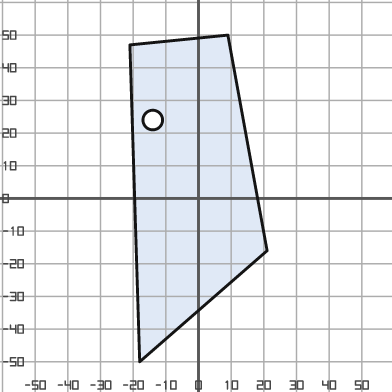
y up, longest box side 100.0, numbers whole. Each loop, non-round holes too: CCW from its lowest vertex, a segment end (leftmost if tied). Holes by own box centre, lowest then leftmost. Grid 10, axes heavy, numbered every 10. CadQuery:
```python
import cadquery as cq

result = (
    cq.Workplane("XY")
    .moveTo(-18.0, -50.0)
    .lineTo(21.0, -16.0)
    .lineTo(9.0, 50.0)
    .lineTo(-21.0, 47.0)
    .close()
    .moveTo(-14.0, 24.0)
    .circle(3.0)
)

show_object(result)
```